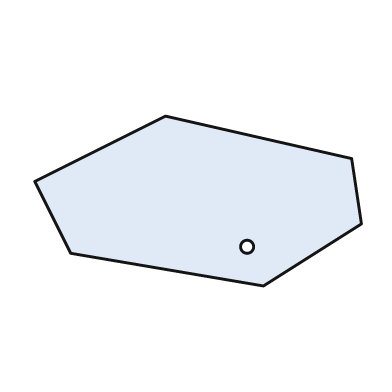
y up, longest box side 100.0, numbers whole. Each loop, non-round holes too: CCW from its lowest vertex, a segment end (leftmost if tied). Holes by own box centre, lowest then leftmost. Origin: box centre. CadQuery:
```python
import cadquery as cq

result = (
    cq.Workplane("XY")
    .moveTo(20.0, -26.0)
    .lineTo(50.0, -7.0)
    .lineTo(47.0, 13.0)
    .lineTo(-10.0, 26.0)
    .lineTo(-50.0, 6.0)
    .lineTo(-39.0, -16.0)
    .close()
    .moveTo(15.0, -14.0)
    .circle(2.0)
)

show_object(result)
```